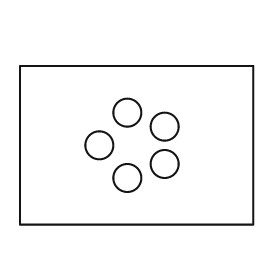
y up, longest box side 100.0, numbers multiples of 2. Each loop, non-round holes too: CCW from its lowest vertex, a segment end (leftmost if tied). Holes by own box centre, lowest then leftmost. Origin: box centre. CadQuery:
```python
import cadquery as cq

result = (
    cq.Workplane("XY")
    .moveTo(-50.0, -34.0)
    .lineTo(50.0, -34.0)
    .lineTo(50.0, 34.0)
    .lineTo(-50.0, 34.0)
    .close()
    .moveTo(-4.0, -14.0)
    .circle(6.0)
    .moveTo(12.0, -8.0)
    .circle(6.0)
    .moveTo(-16.0, 0.0)
    .circle(6.0)
    .moveTo(12.0, 8.0)
    .circle(6.0)
    .moveTo(-4.0, 14.0)
    .circle(6.0)
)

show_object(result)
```